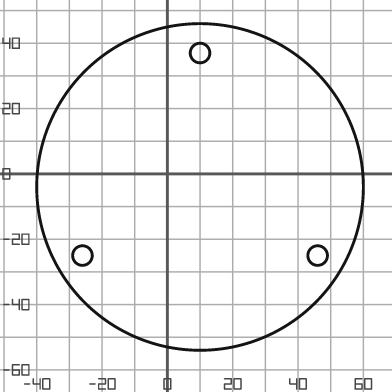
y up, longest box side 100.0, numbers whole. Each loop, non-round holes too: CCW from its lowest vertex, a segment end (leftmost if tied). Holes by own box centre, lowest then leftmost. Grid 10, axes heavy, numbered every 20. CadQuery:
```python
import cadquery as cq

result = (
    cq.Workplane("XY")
    .moveTo(10.0, -4.0)
    .circle(50.0)
    .moveTo(-26.0, -25.0)
    .circle(3.0)
    .moveTo(46.0, -25.0)
    .circle(3.0)
    .moveTo(10.0, 37.0)
    .circle(3.0)
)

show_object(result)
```